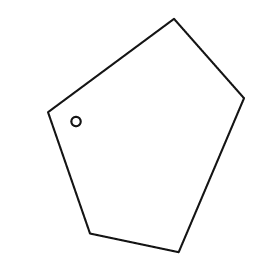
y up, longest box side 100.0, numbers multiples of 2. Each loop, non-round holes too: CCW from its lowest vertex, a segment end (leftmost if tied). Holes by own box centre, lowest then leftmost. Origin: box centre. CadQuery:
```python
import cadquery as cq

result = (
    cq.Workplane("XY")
    .moveTo(14.0, -50.0)
    .lineTo(42.0, 16.0)
    .lineTo(12.0, 50.0)
    .lineTo(-42.0, 10.0)
    .lineTo(-24.0, -42.0)
    .close()
    .moveTo(-30.0, 6.0)
    .circle(2.0)
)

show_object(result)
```